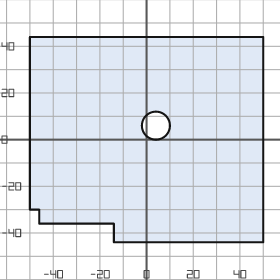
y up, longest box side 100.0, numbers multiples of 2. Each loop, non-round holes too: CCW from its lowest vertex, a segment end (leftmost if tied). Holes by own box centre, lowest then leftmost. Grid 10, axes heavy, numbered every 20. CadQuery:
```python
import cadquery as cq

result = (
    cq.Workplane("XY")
    .moveTo(-14.0, -44.0)
    .lineTo(50.0, -44.0)
    .lineTo(50.0, 44.0)
    .lineTo(-50.0, 44.0)
    .lineTo(-50.0, -30.0)
    .lineTo(-46.0, -30.0)
    .lineTo(-46.0, -36.0)
    .lineTo(-14.0, -36.0)
    .close()
    .moveTo(4.0, 6.0)
    .circle(6.0)
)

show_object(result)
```